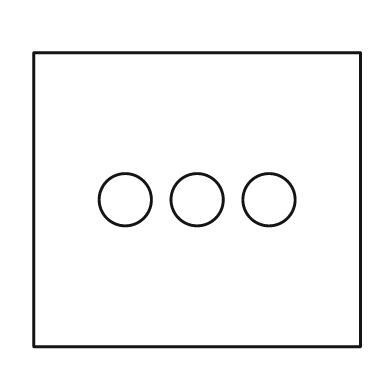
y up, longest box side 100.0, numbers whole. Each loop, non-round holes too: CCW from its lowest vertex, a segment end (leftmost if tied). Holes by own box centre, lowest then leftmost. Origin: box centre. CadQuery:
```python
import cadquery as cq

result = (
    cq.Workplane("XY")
    .moveTo(-50.0, -45.0)
    .lineTo(50.0, -45.0)
    .lineTo(50.0, 45.0)
    .lineTo(-50.0, 45.0)
    .close()
    .moveTo(-22.0, 0.0)
    .circle(8.0)
    .moveTo(0.0, 0.0)
    .circle(8.0)
    .moveTo(22.0, 0.0)
    .circle(8.0)
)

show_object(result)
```